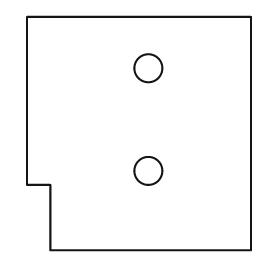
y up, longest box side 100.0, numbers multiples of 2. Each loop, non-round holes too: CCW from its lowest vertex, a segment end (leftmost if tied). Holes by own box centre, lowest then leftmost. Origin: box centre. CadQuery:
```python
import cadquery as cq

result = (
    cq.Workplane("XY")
    .moveTo(-38.0, -50.0)
    .lineTo(48.0, -50.0)
    .lineTo(48.0, 50.0)
    .lineTo(-48.0, 50.0)
    .lineTo(-48.0, -22.0)
    .lineTo(-38.0, -22.0)
    .close()
    .moveTo(4.0, -16.0)
    .circle(6.0)
    .moveTo(4.0, 28.0)
    .circle(6.0)
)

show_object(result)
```